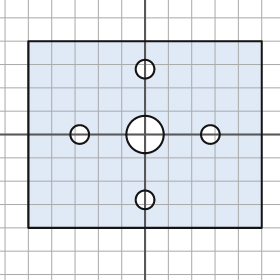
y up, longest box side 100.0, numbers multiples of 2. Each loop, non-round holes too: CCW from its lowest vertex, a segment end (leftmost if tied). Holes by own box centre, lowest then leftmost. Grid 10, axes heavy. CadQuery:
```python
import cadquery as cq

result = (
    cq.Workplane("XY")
    .moveTo(-50.0, -40.0)
    .lineTo(50.0, -40.0)
    .lineTo(50.0, 40.0)
    .lineTo(-50.0, 40.0)
    .close()
    .moveTo(0.0, -28.0)
    .circle(4.0)
    .moveTo(-28.0, 0.0)
    .circle(4.0)
    .moveTo(0.0, 0.0)
    .circle(8.0)
    .moveTo(28.0, 0.0)
    .circle(4.0)
    .moveTo(0.0, 28.0)
    .circle(4.0)
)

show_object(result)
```